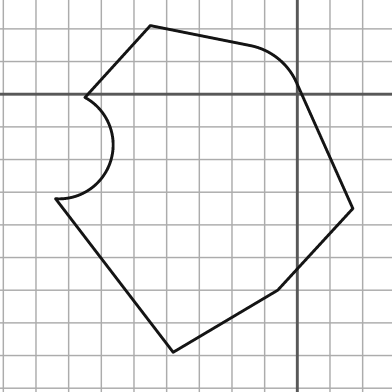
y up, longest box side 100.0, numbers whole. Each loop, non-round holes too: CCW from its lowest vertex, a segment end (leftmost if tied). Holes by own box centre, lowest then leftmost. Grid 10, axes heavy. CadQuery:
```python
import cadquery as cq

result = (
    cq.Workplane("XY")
    .moveTo(-38.0, -79.0)
    .lineTo(-6.0, -60.0)
    .lineTo(17.0, -35.0)
    .lineTo(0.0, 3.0)
    .threePointArc((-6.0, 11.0), (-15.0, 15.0))
    .lineTo(-45.0, 21.0)
    .lineTo(-65.0, -1.0)
    .threePointArc((-57.0, -20.0), (-74.0, -32.0))
    .close()
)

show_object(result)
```